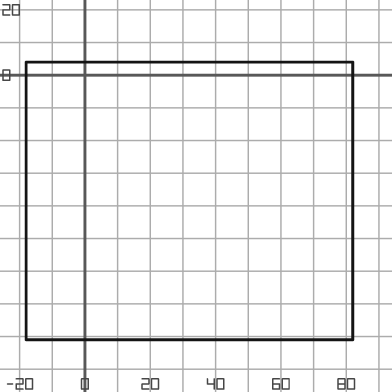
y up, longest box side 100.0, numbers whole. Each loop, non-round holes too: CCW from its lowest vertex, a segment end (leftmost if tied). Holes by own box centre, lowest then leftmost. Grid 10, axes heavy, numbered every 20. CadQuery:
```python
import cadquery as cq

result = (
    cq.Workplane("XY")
    .moveTo(-18.0, -81.0)
    .lineTo(82.0, -81.0)
    .lineTo(82.0, 4.0)
    .lineTo(-18.0, 4.0)
    .close()
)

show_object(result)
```